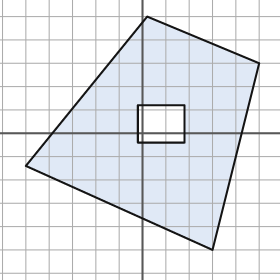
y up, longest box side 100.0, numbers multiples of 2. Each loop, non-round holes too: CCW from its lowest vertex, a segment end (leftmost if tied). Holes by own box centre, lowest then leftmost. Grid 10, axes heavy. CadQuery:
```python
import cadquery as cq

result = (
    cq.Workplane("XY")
    .moveTo(30.0, -50.0)
    .lineTo(50.0, 30.0)
    .lineTo(2.0, 50.0)
    .lineTo(-50.0, -14.0)
    .close()
    .moveTo(-2.0, -4.0)
    .lineTo(18.0, -4.0)
    .lineTo(18.0, 12.0)
    .lineTo(-2.0, 12.0)
    .close()
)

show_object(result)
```